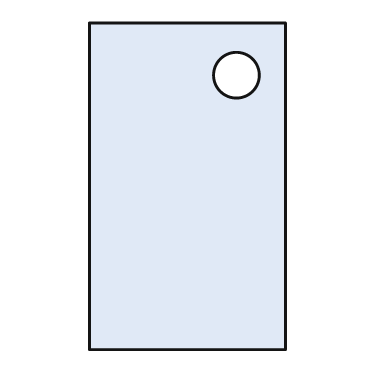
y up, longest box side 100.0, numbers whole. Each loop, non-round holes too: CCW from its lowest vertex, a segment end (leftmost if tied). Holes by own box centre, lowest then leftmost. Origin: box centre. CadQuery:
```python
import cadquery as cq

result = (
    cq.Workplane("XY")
    .moveTo(-30.0, -50.0)
    .lineTo(30.0, -50.0)
    .lineTo(30.0, 50.0)
    .lineTo(-30.0, 50.0)
    .close()
    .moveTo(15.0, 34.0)
    .circle(7.0)
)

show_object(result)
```